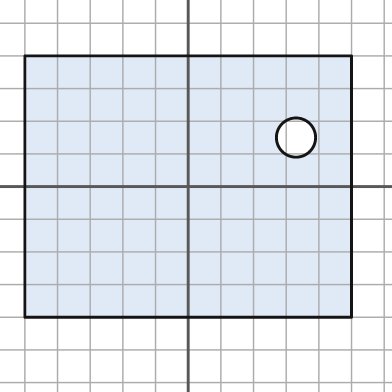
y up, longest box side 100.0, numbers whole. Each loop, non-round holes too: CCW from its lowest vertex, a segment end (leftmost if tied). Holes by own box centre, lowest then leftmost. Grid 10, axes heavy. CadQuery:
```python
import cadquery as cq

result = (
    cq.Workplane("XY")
    .moveTo(-50.0, -40.0)
    .lineTo(50.0, -40.0)
    .lineTo(50.0, 40.0)
    .lineTo(-50.0, 40.0)
    .close()
    .moveTo(33.0, 15.0)
    .circle(6.0)
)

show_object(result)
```